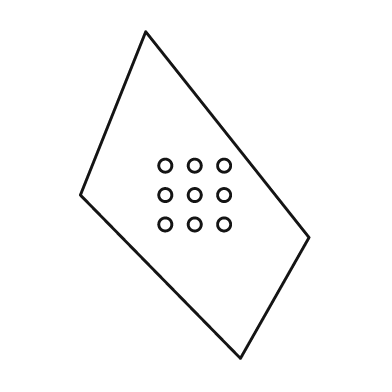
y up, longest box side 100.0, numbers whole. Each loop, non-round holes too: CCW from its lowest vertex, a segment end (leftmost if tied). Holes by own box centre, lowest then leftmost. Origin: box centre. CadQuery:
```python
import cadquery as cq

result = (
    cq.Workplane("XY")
    .moveTo(14.0, -50.0)
    .lineTo(35.0, -13.0)
    .lineTo(-15.0, 50.0)
    .lineTo(-35.0, 0.0)
    .close()
    .moveTo(-9.0, -9.0)
    .circle(2.0)
    .moveTo(0.0, -9.0)
    .circle(2.0)
    .moveTo(9.0, -9.0)
    .circle(2.0)
    .moveTo(-9.0, 0.0)
    .circle(2.0)
    .moveTo(0.0, 0.0)
    .circle(2.0)
    .moveTo(9.0, 0.0)
    .circle(2.0)
    .moveTo(-9.0, 9.0)
    .circle(2.0)
    .moveTo(0.0, 9.0)
    .circle(2.0)
    .moveTo(9.0, 9.0)
    .circle(2.0)
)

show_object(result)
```